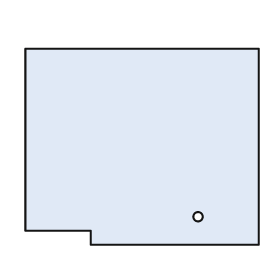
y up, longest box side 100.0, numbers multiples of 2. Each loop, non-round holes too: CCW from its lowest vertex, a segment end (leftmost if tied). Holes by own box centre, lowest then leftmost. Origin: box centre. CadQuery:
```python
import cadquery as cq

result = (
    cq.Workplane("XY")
    .moveTo(-22.0, -42.0)
    .lineTo(50.0, -42.0)
    .lineTo(50.0, 42.0)
    .lineTo(-50.0, 42.0)
    .lineTo(-50.0, -36.0)
    .lineTo(-22.0, -36.0)
    .close()
    .moveTo(24.0, -30.0)
    .circle(2.0)
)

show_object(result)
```